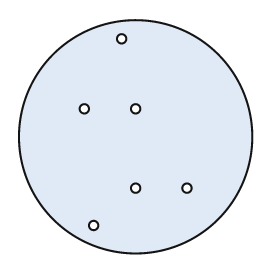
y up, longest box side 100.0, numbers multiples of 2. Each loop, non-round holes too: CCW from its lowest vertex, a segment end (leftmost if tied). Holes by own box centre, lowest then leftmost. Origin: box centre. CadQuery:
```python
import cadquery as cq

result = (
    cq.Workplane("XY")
    .moveTo(0.0, 0.0)
    .circle(50.0)
    .moveTo(-18.0, -38.0)
    .circle(2.0)
    .moveTo(0.0, -22.0)
    .circle(2.0)
    .moveTo(22.0, -22.0)
    .circle(2.0)
    .moveTo(-22.0, 12.0)
    .circle(2.0)
    .moveTo(0.0, 12.0)
    .circle(2.0)
    .moveTo(-6.0, 42.0)
    .circle(2.0)
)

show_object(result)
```